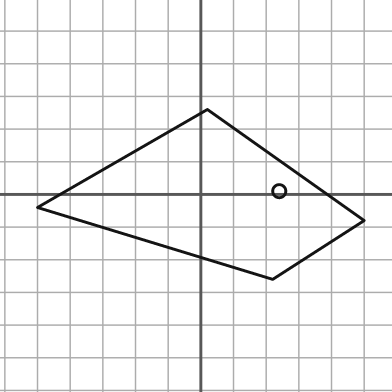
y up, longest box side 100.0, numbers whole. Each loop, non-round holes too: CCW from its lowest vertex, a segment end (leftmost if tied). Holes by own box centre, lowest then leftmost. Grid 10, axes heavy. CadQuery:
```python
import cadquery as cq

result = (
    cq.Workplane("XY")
    .moveTo(22.0, -26.0)
    .lineTo(50.0, -8.0)
    .lineTo(2.0, 26.0)
    .lineTo(-50.0, -4.0)
    .close()
    .moveTo(24.0, 1.0)
    .circle(2.0)
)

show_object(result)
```